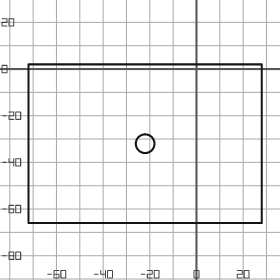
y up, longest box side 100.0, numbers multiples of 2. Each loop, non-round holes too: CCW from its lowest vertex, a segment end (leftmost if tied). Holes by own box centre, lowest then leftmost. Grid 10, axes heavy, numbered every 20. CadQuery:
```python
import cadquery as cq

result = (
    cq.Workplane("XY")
    .moveTo(-72.0, -66.0)
    .lineTo(28.0, -66.0)
    .lineTo(28.0, 2.0)
    .lineTo(-72.0, 2.0)
    .close()
    .moveTo(-22.0, -32.0)
    .circle(4.0)
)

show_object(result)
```